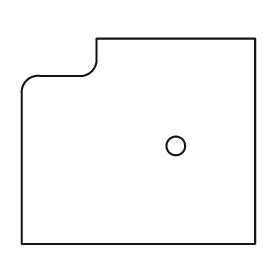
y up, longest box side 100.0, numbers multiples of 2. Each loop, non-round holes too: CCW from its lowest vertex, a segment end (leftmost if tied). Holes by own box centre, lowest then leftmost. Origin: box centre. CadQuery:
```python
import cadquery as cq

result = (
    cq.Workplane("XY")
    .moveTo(-50.0, -44.0)
    .lineTo(50.0, -44.0)
    .lineTo(50.0, 44.0)
    .lineTo(-18.0, 44.0)
    .lineTo(-18.0, 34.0)
    .threePointArc((-20.0, 30.0), (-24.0, 28.0))
    .lineTo(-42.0, 28.0)
    .threePointArc((-48.0, 26.0), (-50.0, 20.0))
    .close()
    .moveTo(16.0, -2.0)
    .circle(4.0)
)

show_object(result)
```